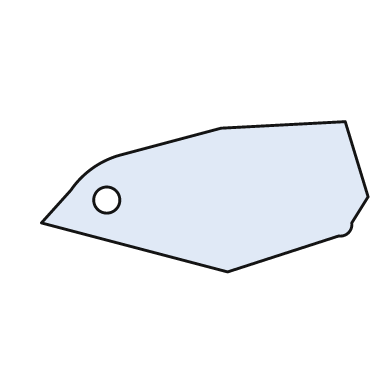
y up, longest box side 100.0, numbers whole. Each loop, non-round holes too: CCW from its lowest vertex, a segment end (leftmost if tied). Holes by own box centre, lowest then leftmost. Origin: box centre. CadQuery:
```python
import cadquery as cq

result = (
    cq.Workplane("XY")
    .moveTo(7.0, -23.0)
    .lineTo(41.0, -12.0)
    .threePointArc((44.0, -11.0), (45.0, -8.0))
    .lineTo(50.0, 0.0)
    .lineTo(43.0, 23.0)
    .lineTo(5.0, 21.0)
    .lineTo(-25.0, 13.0)
    .threePointArc((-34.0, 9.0), (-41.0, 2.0))
    .lineTo(-50.0, -8.0)
    .close()
    .moveTo(-30.0, -1.0)
    .circle(4.0)
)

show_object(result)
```